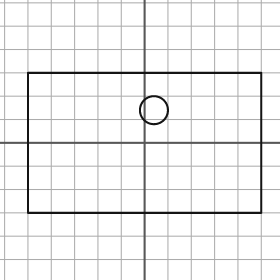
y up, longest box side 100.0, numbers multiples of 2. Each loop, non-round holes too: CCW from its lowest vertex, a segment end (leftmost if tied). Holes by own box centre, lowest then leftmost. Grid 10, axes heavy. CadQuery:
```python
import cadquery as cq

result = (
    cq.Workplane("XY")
    .moveTo(-50.0, -30.0)
    .lineTo(50.0, -30.0)
    .lineTo(50.0, 30.0)
    .lineTo(-50.0, 30.0)
    .close()
    .moveTo(4.0, 14.0)
    .circle(6.0)
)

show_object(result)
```